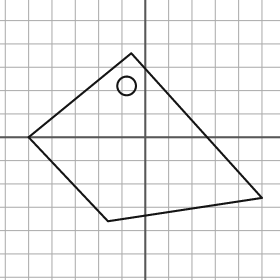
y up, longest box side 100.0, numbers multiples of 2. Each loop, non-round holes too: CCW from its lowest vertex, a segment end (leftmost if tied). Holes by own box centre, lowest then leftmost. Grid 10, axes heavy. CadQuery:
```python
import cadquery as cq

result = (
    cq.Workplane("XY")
    .moveTo(-16.0, -36.0)
    .lineTo(50.0, -26.0)
    .lineTo(-6.0, 36.0)
    .lineTo(-50.0, 0.0)
    .close()
    .moveTo(-8.0, 22.0)
    .circle(4.0)
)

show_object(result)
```